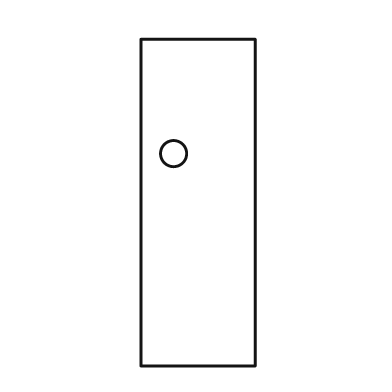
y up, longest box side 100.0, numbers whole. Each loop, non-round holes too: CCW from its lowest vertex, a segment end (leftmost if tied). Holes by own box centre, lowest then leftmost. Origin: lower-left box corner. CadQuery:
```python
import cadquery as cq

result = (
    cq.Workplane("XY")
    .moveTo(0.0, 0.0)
    .lineTo(35.0, 0.0)
    .lineTo(35.0, 100.0)
    .lineTo(0.0, 100.0)
    .close()
    .moveTo(10.0, 65.0)
    .circle(4.0)
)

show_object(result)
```